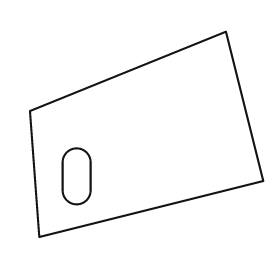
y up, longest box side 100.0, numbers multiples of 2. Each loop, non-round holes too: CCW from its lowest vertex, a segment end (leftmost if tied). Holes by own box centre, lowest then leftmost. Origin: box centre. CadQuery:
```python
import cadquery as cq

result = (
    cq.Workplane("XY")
    .moveTo(-46.0, -44.0)
    .lineTo(50.0, -20.0)
    .lineTo(34.0, 44.0)
    .lineTo(-50.0, 10.0)
    .close()
    .moveTo(-36.0, -24.0)
    .threePointArc((-30.0, -30.0), (-24.0, -24.0))
    .lineTo(-24.0, -12.0)
    .threePointArc((-30.0, -6.0), (-36.0, -12.0))
    .close()
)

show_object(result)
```